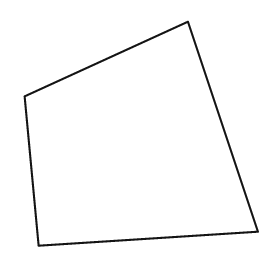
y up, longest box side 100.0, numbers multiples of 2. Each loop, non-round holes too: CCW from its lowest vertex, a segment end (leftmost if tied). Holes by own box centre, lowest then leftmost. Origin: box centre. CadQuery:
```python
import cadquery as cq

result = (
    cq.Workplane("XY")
    .moveTo(-44.0, -48.0)
    .lineTo(50.0, -42.0)
    .lineTo(20.0, 48.0)
    .lineTo(-50.0, 16.0)
    .close()
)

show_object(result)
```